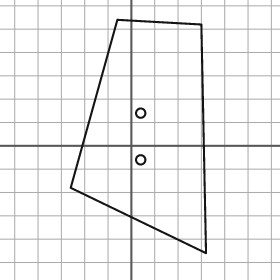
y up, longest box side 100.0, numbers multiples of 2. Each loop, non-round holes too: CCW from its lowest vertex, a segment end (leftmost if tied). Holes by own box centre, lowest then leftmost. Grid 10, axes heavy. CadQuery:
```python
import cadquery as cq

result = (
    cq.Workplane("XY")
    .moveTo(32.0, -46.0)
    .lineTo(30.0, 52.0)
    .lineTo(-6.0, 54.0)
    .lineTo(-26.0, -18.0)
    .close()
    .moveTo(4.0, -6.0)
    .circle(2.0)
    .moveTo(4.0, 14.0)
    .circle(2.0)
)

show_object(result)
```